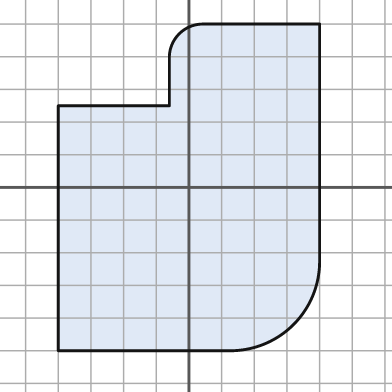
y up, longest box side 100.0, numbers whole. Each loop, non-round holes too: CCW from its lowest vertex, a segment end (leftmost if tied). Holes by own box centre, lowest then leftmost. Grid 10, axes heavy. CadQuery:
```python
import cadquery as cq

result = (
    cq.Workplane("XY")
    .moveTo(-40.0, -50.0)
    .lineTo(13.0, -50.0)
    .threePointArc((32.0, -42.0), (40.0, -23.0))
    .lineTo(40.0, 50.0)
    .lineTo(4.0, 50.0)
    .threePointArc((-3.0, 47.0), (-6.0, 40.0))
    .lineTo(-6.0, 25.0)
    .lineTo(-40.0, 25.0)
    .close()
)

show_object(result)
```